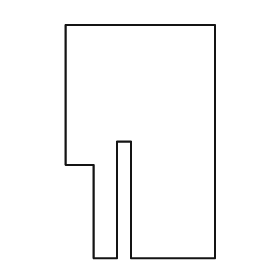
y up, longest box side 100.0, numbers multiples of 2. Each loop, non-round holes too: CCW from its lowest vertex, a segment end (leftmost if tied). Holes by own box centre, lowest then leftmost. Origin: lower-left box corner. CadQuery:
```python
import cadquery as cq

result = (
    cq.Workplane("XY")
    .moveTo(12.0, 0.0)
    .lineTo(22.0, 0.0)
    .lineTo(22.0, 50.0)
    .lineTo(28.0, 50.0)
    .lineTo(28.0, 0.0)
    .lineTo(64.0, 0.0)
    .lineTo(64.0, 100.0)
    .lineTo(0.0, 100.0)
    .lineTo(0.0, 40.0)
    .lineTo(12.0, 40.0)
    .close()
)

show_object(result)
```